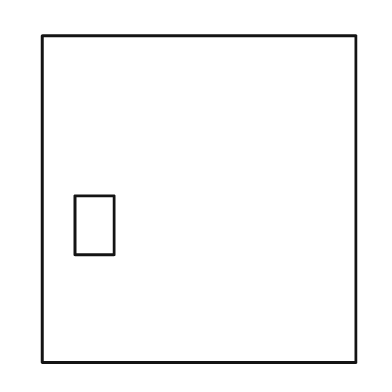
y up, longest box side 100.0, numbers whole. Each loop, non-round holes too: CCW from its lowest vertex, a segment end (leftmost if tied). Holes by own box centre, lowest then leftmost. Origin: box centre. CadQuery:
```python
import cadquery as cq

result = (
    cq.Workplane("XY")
    .moveTo(-48.0, -50.0)
    .lineTo(48.0, -50.0)
    .lineTo(48.0, 50.0)
    .lineTo(-48.0, 50.0)
    .close()
    .moveTo(-38.0, -17.0)
    .lineTo(-26.0, -17.0)
    .lineTo(-26.0, 1.0)
    .lineTo(-38.0, 1.0)
    .close()
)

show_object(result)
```